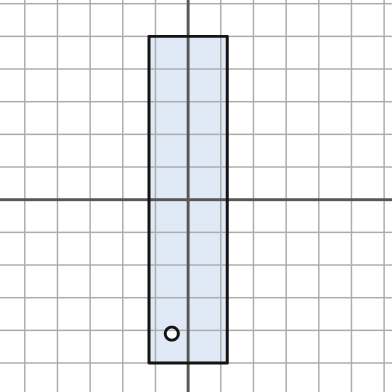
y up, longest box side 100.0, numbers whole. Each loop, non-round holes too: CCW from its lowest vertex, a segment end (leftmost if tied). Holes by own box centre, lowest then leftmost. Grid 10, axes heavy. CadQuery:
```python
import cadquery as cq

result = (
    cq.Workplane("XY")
    .moveTo(-12.0, -50.0)
    .lineTo(12.0, -50.0)
    .lineTo(12.0, 50.0)
    .lineTo(-12.0, 50.0)
    .close()
    .moveTo(-5.0, -41.0)
    .circle(2.0)
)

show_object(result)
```